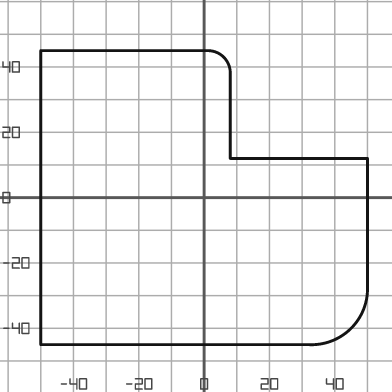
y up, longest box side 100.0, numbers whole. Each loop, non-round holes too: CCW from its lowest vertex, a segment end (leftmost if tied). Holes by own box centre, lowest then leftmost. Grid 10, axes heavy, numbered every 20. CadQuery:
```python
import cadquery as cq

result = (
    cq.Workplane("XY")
    .moveTo(-50.0, -45.0)
    .lineTo(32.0, -45.0)
    .threePointArc((45.0, -40.0), (50.0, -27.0))
    .lineTo(50.0, 12.0)
    .lineTo(8.0, 12.0)
    .lineTo(8.0, 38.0)
    .threePointArc((6.0, 43.0), (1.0, 45.0))
    .lineTo(-50.0, 45.0)
    .close()
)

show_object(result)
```